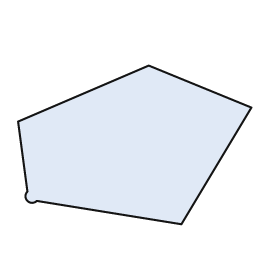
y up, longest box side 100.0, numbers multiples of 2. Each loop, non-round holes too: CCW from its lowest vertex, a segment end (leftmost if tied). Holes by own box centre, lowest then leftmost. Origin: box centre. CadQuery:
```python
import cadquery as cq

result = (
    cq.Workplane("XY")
    .moveTo(20.0, -34.0)
    .lineTo(50.0, 16.0)
    .lineTo(6.0, 34.0)
    .lineTo(-50.0, 10.0)
    .lineTo(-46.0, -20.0)
    .threePointArc((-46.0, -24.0), (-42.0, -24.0))
    .close()
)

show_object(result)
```